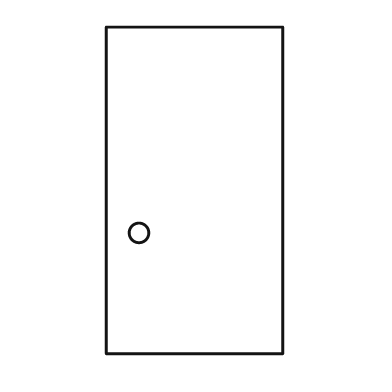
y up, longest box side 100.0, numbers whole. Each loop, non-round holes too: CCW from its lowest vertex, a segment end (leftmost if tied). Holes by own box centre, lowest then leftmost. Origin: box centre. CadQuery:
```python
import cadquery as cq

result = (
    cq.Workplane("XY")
    .moveTo(-27.0, -50.0)
    .lineTo(27.0, -50.0)
    .lineTo(27.0, 50.0)
    .lineTo(-27.0, 50.0)
    .close()
    .moveTo(-17.0, -13.0)
    .circle(3.0)
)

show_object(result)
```